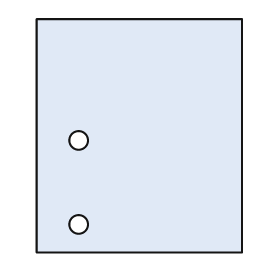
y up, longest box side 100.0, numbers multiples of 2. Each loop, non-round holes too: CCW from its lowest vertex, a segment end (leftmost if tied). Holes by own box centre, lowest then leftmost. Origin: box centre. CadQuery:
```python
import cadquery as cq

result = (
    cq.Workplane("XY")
    .moveTo(-44.0, -50.0)
    .lineTo(44.0, -50.0)
    .lineTo(44.0, 50.0)
    .lineTo(-44.0, 50.0)
    .close()
    .moveTo(-26.0, -38.0)
    .circle(4.0)
    .moveTo(-26.0, -2.0)
    .circle(4.0)
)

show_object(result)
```